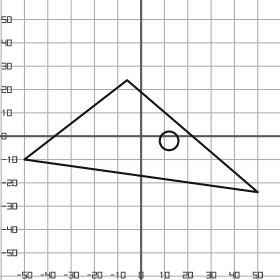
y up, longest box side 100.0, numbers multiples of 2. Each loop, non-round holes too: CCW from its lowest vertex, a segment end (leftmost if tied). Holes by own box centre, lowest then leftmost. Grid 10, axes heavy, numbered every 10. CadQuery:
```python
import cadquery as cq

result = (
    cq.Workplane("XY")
    .moveTo(50.0, -24.0)
    .lineTo(-6.0, 24.0)
    .lineTo(-50.0, -10.0)
    .close()
    .moveTo(12.0, -2.0)
    .circle(4.0)
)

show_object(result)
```